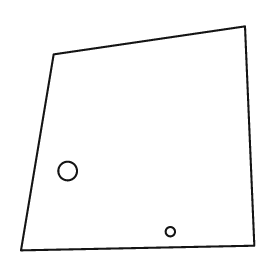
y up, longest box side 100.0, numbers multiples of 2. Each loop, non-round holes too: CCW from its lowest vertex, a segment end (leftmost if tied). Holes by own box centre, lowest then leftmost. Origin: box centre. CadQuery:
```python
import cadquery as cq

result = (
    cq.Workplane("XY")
    .moveTo(-50.0, -48.0)
    .lineTo(50.0, -46.0)
    .lineTo(46.0, 48.0)
    .lineTo(-36.0, 36.0)
    .close()
    .moveTo(14.0, -40.0)
    .circle(2.0)
    .moveTo(-30.0, -14.0)
    .circle(4.0)
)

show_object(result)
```